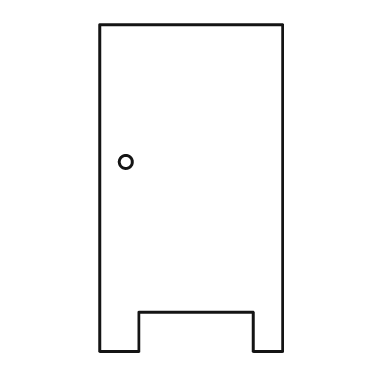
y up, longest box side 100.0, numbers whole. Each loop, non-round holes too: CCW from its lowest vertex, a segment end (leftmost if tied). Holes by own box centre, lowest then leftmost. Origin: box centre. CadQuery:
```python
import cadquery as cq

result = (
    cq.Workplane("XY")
    .moveTo(-28.0, -50.0)
    .lineTo(-16.0, -50.0)
    .lineTo(-16.0, -38.0)
    .lineTo(19.0, -38.0)
    .lineTo(19.0, -50.0)
    .lineTo(28.0, -50.0)
    .lineTo(28.0, 50.0)
    .lineTo(-28.0, 50.0)
    .close()
    .moveTo(-20.0, 8.0)
    .circle(2.0)
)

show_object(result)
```